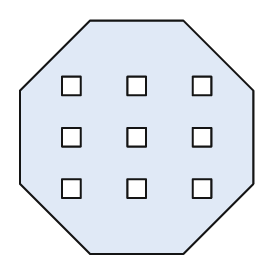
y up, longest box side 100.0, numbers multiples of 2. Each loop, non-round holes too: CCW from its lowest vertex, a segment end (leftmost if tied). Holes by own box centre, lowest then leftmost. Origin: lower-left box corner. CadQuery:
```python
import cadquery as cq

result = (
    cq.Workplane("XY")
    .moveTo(30.0, 0.0)
    .lineTo(70.0, 0.0)
    .lineTo(100.0, 30.0)
    .lineTo(100.0, 70.0)
    .lineTo(70.0, 100.0)
    .lineTo(30.0, 100.0)
    .lineTo(0.0, 70.0)
    .lineTo(0.0, 30.0)
    .close()
    .moveTo(18.0, 24.0)
    .lineTo(26.0, 24.0)
    .lineTo(26.0, 32.0)
    .lineTo(18.0, 32.0)
    .close()
    .moveTo(46.0, 24.0)
    .lineTo(54.0, 24.0)
    .lineTo(54.0, 32.0)
    .lineTo(46.0, 32.0)
    .close()
    .moveTo(74.0, 24.0)
    .lineTo(82.0, 24.0)
    .lineTo(82.0, 32.0)
    .lineTo(74.0, 32.0)
    .close()
    .moveTo(18.0, 46.0)
    .lineTo(26.0, 46.0)
    .lineTo(26.0, 54.0)
    .lineTo(18.0, 54.0)
    .close()
    .moveTo(46.0, 46.0)
    .lineTo(54.0, 46.0)
    .lineTo(54.0, 54.0)
    .lineTo(46.0, 54.0)
    .close()
    .moveTo(74.0, 46.0)
    .lineTo(82.0, 46.0)
    .lineTo(82.0, 54.0)
    .lineTo(74.0, 54.0)
    .close()
    .moveTo(18.0, 68.0)
    .lineTo(26.0, 68.0)
    .lineTo(26.0, 76.0)
    .lineTo(18.0, 76.0)
    .close()
    .moveTo(46.0, 68.0)
    .lineTo(54.0, 68.0)
    .lineTo(54.0, 76.0)
    .lineTo(46.0, 76.0)
    .close()
    .moveTo(74.0, 68.0)
    .lineTo(82.0, 68.0)
    .lineTo(82.0, 76.0)
    .lineTo(74.0, 76.0)
    .close()
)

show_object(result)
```